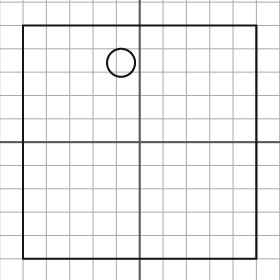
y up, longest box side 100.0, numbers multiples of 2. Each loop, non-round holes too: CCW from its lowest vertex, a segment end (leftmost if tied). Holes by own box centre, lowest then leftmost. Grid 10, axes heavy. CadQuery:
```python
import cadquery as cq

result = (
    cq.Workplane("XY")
    .moveTo(-50.0, -50.0)
    .lineTo(50.0, -50.0)
    .lineTo(50.0, 50.0)
    .lineTo(-50.0, 50.0)
    .close()
    .moveTo(-8.0, 34.0)
    .circle(6.0)
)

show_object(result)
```